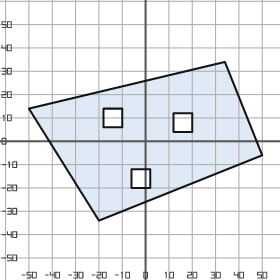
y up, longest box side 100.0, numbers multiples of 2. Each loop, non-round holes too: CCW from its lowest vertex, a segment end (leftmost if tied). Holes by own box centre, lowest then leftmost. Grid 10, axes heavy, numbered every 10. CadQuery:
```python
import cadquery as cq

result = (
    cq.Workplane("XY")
    .moveTo(-20.0, -34.0)
    .lineTo(50.0, -6.0)
    .lineTo(34.0, 34.0)
    .lineTo(-50.0, 14.0)
    .close()
    .moveTo(-6.0, -20.0)
    .lineTo(2.0, -20.0)
    .lineTo(2.0, -12.0)
    .lineTo(-6.0, -12.0)
    .close()
    .moveTo(12.0, 4.0)
    .lineTo(20.0, 4.0)
    .lineTo(20.0, 12.0)
    .lineTo(12.0, 12.0)
    .close()
    .moveTo(-18.0, 6.0)
    .lineTo(-10.0, 6.0)
    .lineTo(-10.0, 14.0)
    .lineTo(-18.0, 14.0)
    .close()
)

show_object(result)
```